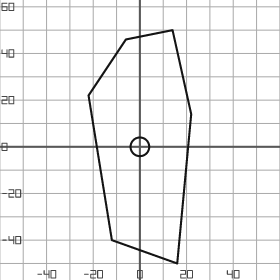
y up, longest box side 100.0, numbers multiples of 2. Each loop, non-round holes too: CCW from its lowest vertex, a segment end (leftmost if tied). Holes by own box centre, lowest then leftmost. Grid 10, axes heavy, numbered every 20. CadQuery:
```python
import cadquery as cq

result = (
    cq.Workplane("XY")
    .moveTo(16.0, -50.0)
    .lineTo(22.0, 14.0)
    .lineTo(14.0, 50.0)
    .lineTo(-6.0, 46.0)
    .lineTo(-22.0, 22.0)
    .lineTo(-12.0, -40.0)
    .close()
    .moveTo(0.0, 0.0)
    .circle(4.0)
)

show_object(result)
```